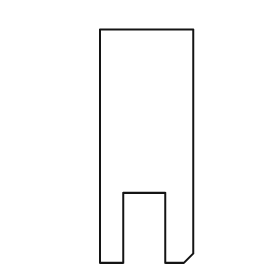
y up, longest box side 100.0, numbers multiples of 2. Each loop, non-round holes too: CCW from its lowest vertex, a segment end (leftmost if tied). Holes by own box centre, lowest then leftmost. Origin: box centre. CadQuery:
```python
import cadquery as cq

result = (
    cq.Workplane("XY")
    .moveTo(-20.0, -50.0)
    .lineTo(-10.0, -50.0)
    .lineTo(-10.0, -20.0)
    .lineTo(8.0, -20.0)
    .lineTo(8.0, -50.0)
    .lineTo(16.0, -50.0)
    .lineTo(20.0, -46.0)
    .lineTo(20.0, 50.0)
    .lineTo(-20.0, 50.0)
    .close()
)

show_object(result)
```